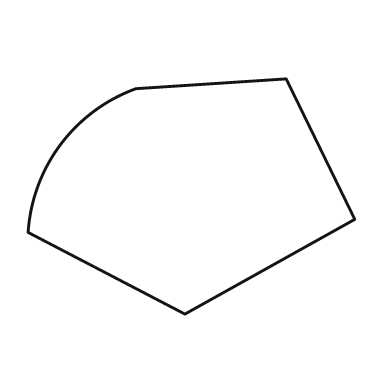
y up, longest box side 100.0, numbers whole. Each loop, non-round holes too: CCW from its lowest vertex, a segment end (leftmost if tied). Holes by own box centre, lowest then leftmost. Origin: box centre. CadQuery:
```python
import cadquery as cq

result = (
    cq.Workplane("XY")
    .moveTo(-2.0, -36.0)
    .lineTo(50.0, -7.0)
    .lineTo(29.0, 36.0)
    .lineTo(-17.0, 33.0)
    .threePointArc((-40.0, 16.0), (-50.0, -11.0))
    .close()
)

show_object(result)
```